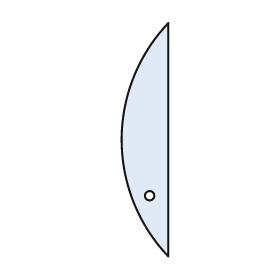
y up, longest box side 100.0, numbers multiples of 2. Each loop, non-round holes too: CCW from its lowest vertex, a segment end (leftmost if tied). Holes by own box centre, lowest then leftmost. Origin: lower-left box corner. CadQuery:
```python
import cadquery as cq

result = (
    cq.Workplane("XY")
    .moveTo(20.0, 0.0)
    .lineTo(20.0, 100.0)
    .threePointArc((0.0, 50.0), (20.0, 0.0))
    .close()
    .moveTo(12.0, 26.0)
    .circle(2.0)
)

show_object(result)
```